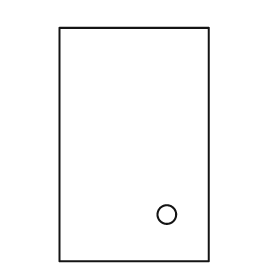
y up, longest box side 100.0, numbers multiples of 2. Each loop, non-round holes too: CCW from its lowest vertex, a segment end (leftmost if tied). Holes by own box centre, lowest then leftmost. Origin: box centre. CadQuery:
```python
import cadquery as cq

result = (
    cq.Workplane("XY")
    .moveTo(-32.0, -50.0)
    .lineTo(32.0, -50.0)
    .lineTo(32.0, 50.0)
    .lineTo(-32.0, 50.0)
    .close()
    .moveTo(14.0, -30.0)
    .circle(4.0)
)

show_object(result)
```